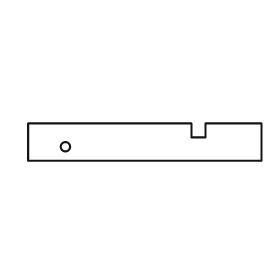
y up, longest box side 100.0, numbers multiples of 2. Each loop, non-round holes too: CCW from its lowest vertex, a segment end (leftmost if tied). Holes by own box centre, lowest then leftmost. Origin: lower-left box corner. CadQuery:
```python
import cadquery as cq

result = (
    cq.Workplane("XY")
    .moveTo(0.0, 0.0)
    .lineTo(100.0, 0.0)
    .lineTo(100.0, 16.0)
    .lineTo(76.0, 16.0)
    .lineTo(76.0, 10.0)
    .lineTo(70.0, 10.0)
    .lineTo(70.0, 16.0)
    .lineTo(0.0, 16.0)
    .close()
    .moveTo(16.0, 6.0)
    .circle(2.0)
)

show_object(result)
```